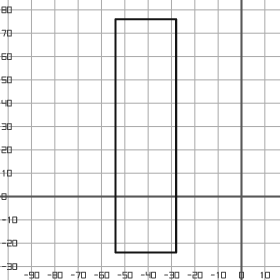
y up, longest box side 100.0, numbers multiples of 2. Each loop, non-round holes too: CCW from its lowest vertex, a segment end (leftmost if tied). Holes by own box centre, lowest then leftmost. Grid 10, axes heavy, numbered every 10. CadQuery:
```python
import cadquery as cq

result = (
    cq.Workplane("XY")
    .moveTo(-54.0, -24.0)
    .lineTo(-28.0, -24.0)
    .lineTo(-28.0, 76.0)
    .lineTo(-54.0, 76.0)
    .close()
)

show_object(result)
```